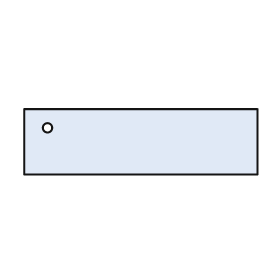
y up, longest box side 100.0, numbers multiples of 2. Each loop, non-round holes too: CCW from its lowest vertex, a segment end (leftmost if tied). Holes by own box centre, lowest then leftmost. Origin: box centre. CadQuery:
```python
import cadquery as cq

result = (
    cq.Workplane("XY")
    .moveTo(-50.0, -14.0)
    .lineTo(50.0, -14.0)
    .lineTo(50.0, 14.0)
    .lineTo(-50.0, 14.0)
    .close()
    .moveTo(-40.0, 6.0)
    .circle(2.0)
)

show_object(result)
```